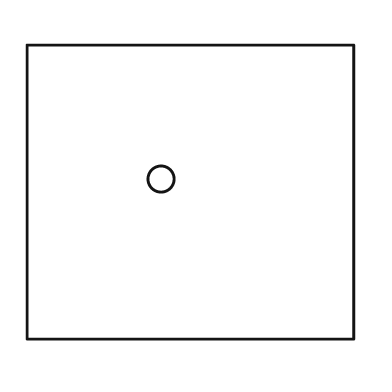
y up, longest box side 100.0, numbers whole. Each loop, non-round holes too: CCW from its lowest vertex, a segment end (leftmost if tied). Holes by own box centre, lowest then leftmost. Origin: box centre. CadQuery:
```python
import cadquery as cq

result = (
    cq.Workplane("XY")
    .moveTo(-50.0, -45.0)
    .lineTo(50.0, -45.0)
    .lineTo(50.0, 45.0)
    .lineTo(-50.0, 45.0)
    .close()
    .moveTo(-9.0, 4.0)
    .circle(4.0)
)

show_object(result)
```